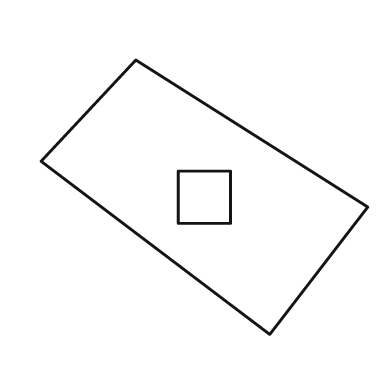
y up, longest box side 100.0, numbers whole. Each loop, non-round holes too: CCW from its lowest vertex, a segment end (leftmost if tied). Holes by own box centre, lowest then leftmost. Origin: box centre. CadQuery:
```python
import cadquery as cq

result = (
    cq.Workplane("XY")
    .moveTo(20.0, -42.0)
    .lineTo(50.0, -3.0)
    .lineTo(-21.0, 42.0)
    .lineTo(-50.0, 11.0)
    .close()
    .moveTo(-8.0, -8.0)
    .lineTo(8.0, -8.0)
    .lineTo(8.0, 8.0)
    .lineTo(-8.0, 8.0)
    .close()
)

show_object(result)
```